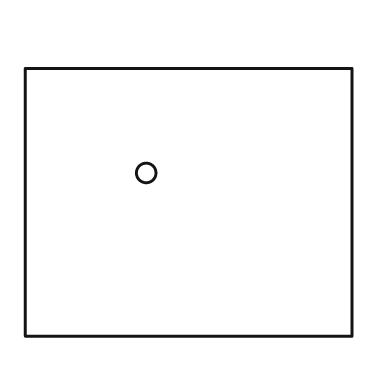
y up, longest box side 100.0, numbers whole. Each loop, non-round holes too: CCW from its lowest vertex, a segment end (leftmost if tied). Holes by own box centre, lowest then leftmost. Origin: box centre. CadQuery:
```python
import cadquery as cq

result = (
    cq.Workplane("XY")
    .moveTo(-50.0, -41.0)
    .lineTo(50.0, -41.0)
    .lineTo(50.0, 41.0)
    .lineTo(-50.0, 41.0)
    .close()
    .moveTo(-13.0, 9.0)
    .circle(3.0)
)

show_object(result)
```